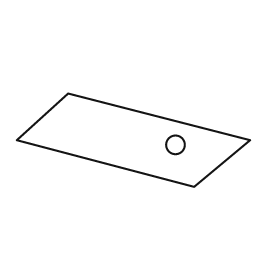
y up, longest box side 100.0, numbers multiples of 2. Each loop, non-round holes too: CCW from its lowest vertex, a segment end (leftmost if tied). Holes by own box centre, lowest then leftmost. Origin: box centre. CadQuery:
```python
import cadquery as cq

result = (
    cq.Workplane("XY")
    .moveTo(26.0, -20.0)
    .lineTo(50.0, 0.0)
    .lineTo(-28.0, 20.0)
    .lineTo(-50.0, 0.0)
    .close()
    .moveTo(18.0, -2.0)
    .circle(4.0)
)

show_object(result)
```